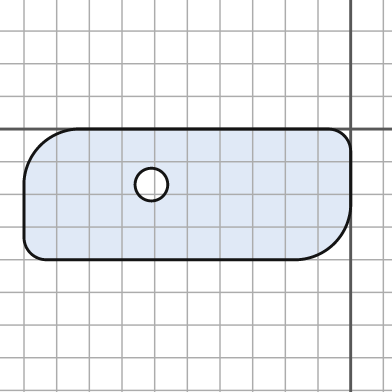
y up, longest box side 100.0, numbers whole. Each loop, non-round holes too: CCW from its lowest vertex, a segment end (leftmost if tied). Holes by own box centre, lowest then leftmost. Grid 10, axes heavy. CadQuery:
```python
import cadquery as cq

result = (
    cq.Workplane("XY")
    .moveTo(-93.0, -40.0)
    .lineTo(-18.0, -40.0)
    .threePointArc((-5.0, -35.0), (0.0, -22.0))
    .lineTo(0.0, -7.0)
    .threePointArc((-2.0, -2.0), (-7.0, 0.0))
    .lineTo(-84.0, 0.0)
    .threePointArc((-95.0, -5.0), (-100.0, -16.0))
    .lineTo(-100.0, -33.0)
    .threePointArc((-98.0, -38.0), (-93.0, -40.0))
    .close()
    .moveTo(-61.0, -17.0)
    .circle(5.0)
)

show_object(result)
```